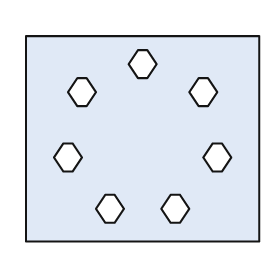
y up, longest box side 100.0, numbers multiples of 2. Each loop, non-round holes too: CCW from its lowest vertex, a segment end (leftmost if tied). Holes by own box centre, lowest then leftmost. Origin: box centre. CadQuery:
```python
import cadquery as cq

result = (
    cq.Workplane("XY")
    .moveTo(-50.0, -44.0)
    .lineTo(50.0, -44.0)
    .lineTo(50.0, 44.0)
    .lineTo(-50.0, 44.0)
    .close()
    .moveTo(-16.0, -36.0)
    .lineTo(-12.0, -36.0)
    .lineTo(-8.0, -30.0)
    .lineTo(-12.0, -24.0)
    .lineTo(-16.0, -24.0)
    .lineTo(-20.0, -30.0)
    .close()
    .moveTo(12.0, -36.0)
    .lineTo(16.0, -36.0)
    .lineTo(20.0, -30.0)
    .lineTo(16.0, -24.0)
    .lineTo(12.0, -24.0)
    .lineTo(8.0, -30.0)
    .close()
    .moveTo(-34.0, -14.0)
    .lineTo(-30.0, -14.0)
    .lineTo(-26.0, -8.0)
    .lineTo(-30.0, -2.0)
    .lineTo(-34.0, -2.0)
    .lineTo(-38.0, -8.0)
    .close()
    .moveTo(30.0, -14.0)
    .lineTo(34.0, -14.0)
    .lineTo(38.0, -8.0)
    .lineTo(34.0, -2.0)
    .lineTo(30.0, -2.0)
    .lineTo(26.0, -8.0)
    .close()
    .moveTo(-28.0, 14.0)
    .lineTo(-24.0, 14.0)
    .lineTo(-20.0, 20.0)
    .lineTo(-24.0, 26.0)
    .lineTo(-28.0, 26.0)
    .lineTo(-32.0, 20.0)
    .close()
    .moveTo(24.0, 14.0)
    .lineTo(28.0, 14.0)
    .lineTo(32.0, 20.0)
    .lineTo(28.0, 26.0)
    .lineTo(24.0, 26.0)
    .lineTo(20.0, 20.0)
    .close()
    .moveTo(-2.0, 26.0)
    .lineTo(2.0, 26.0)
    .lineTo(6.0, 32.0)
    .lineTo(2.0, 38.0)
    .lineTo(-2.0, 38.0)
    .lineTo(-6.0, 32.0)
    .close()
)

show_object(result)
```